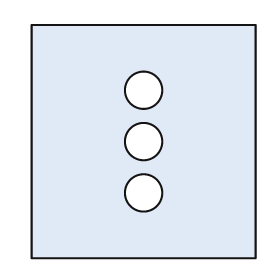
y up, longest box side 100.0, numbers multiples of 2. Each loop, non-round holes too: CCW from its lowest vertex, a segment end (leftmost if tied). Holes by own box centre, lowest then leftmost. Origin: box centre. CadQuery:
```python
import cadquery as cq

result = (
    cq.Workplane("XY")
    .moveTo(-48.0, -50.0)
    .lineTo(48.0, -50.0)
    .lineTo(48.0, 50.0)
    .lineTo(-48.0, 50.0)
    .close()
    .moveTo(0.0, -22.0)
    .circle(8.0)
    .moveTo(0.0, 0.0)
    .circle(8.0)
    .moveTo(0.0, 22.0)
    .circle(8.0)
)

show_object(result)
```